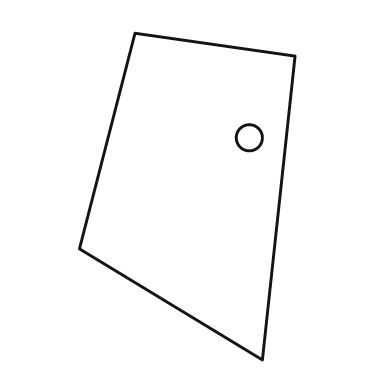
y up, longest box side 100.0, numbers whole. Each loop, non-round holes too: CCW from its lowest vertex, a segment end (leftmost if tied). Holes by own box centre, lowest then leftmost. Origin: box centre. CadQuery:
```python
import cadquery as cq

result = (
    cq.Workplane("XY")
    .moveTo(23.0, -50.0)
    .lineTo(33.0, 43.0)
    .lineTo(-16.0, 50.0)
    .lineTo(-33.0, -16.0)
    .close()
    .moveTo(19.0, 18.0)
    .circle(4.0)
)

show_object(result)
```